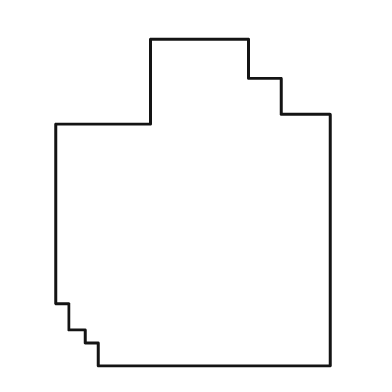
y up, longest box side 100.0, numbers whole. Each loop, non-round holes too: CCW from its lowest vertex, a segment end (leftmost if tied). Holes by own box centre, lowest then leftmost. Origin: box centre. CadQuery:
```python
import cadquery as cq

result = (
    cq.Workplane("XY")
    .moveTo(-29.0, -50.0)
    .lineTo(42.0, -50.0)
    .lineTo(42.0, 27.0)
    .lineTo(27.0, 27.0)
    .lineTo(27.0, 38.0)
    .lineTo(17.0, 38.0)
    .lineTo(17.0, 50.0)
    .lineTo(-13.0, 50.0)
    .lineTo(-13.0, 24.0)
    .lineTo(-42.0, 24.0)
    .lineTo(-42.0, -31.0)
    .lineTo(-38.0, -31.0)
    .lineTo(-38.0, -39.0)
    .lineTo(-33.0, -39.0)
    .lineTo(-33.0, -43.0)
    .lineTo(-29.0, -43.0)
    .close()
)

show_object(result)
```